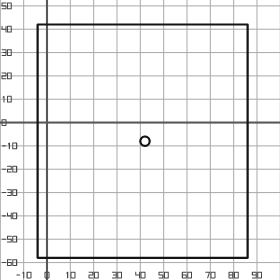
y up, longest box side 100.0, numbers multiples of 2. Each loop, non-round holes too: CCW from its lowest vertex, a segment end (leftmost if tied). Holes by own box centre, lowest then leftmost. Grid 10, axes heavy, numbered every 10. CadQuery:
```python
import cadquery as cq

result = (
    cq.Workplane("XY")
    .moveTo(-4.0, -58.0)
    .lineTo(86.0, -58.0)
    .lineTo(86.0, 42.0)
    .lineTo(-4.0, 42.0)
    .close()
    .moveTo(42.0, -8.0)
    .circle(2.0)
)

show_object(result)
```